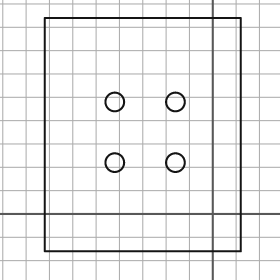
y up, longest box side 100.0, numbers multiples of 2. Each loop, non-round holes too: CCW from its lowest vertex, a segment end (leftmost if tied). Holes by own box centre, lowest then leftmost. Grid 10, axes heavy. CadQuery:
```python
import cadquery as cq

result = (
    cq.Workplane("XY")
    .moveTo(-72.0, -16.0)
    .lineTo(12.0, -16.0)
    .lineTo(12.0, 84.0)
    .lineTo(-72.0, 84.0)
    .close()
    .moveTo(-42.0, 22.0)
    .circle(4.0)
    .moveTo(-16.0, 22.0)
    .circle(4.0)
    .moveTo(-42.0, 48.0)
    .circle(4.0)
    .moveTo(-16.0, 48.0)
    .circle(4.0)
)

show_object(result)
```